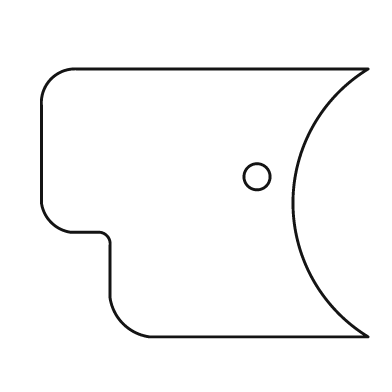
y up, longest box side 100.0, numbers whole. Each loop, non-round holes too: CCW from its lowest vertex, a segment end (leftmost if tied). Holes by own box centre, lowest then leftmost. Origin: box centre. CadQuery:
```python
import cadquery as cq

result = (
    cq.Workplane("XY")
    .moveTo(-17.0, -41.0)
    .lineTo(50.0, -41.0)
    .threePointArc((27.0, 0.0), (50.0, 41.0))
    .lineTo(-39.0, 41.0)
    .threePointArc((-47.0, 38.0), (-50.0, 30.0))
    .lineTo(-50.0, 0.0)
    .threePointArc((-47.0, -6.0), (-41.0, -9.0))
    .lineTo(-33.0, -9.0)
    .threePointArc((-30.0, -10.0), (-29.0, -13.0))
    .lineTo(-29.0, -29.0)
    .threePointArc((-25.0, -37.0), (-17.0, -41.0))
    .close()
    .moveTo(16.0, 8.0)
    .circle(4.0)
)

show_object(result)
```